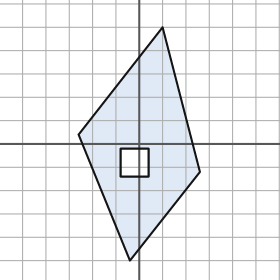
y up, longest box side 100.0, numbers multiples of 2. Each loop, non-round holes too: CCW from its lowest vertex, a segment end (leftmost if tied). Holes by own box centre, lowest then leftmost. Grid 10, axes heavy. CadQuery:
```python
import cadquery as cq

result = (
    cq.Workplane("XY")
    .moveTo(-4.0, -50.0)
    .lineTo(26.0, -12.0)
    .lineTo(10.0, 50.0)
    .lineTo(-26.0, 4.0)
    .close()
    .moveTo(-8.0, -14.0)
    .lineTo(4.0, -14.0)
    .lineTo(4.0, -2.0)
    .lineTo(-8.0, -2.0)
    .close()
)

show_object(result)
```